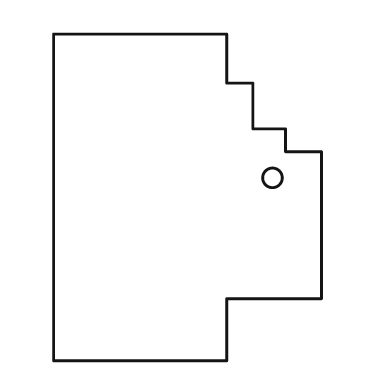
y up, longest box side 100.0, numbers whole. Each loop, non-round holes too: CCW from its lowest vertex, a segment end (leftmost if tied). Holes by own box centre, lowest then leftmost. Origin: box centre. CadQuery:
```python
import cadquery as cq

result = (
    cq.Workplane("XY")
    .moveTo(-41.0, -50.0)
    .lineTo(12.0, -50.0)
    .lineTo(12.0, -31.0)
    .lineTo(41.0, -31.0)
    .lineTo(41.0, 14.0)
    .lineTo(30.0, 14.0)
    .lineTo(30.0, 21.0)
    .lineTo(20.0, 21.0)
    .lineTo(20.0, 35.0)
    .lineTo(12.0, 35.0)
    .lineTo(12.0, 50.0)
    .lineTo(-41.0, 50.0)
    .close()
    .moveTo(26.0, 6.0)
    .circle(3.0)
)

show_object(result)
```